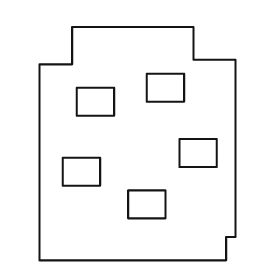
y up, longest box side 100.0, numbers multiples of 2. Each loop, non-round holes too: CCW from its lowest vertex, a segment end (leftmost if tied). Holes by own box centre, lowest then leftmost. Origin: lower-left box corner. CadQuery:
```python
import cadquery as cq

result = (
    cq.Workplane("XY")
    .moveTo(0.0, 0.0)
    .lineTo(80.0, 0.0)
    .lineTo(80.0, 10.0)
    .lineTo(84.0, 10.0)
    .lineTo(84.0, 86.0)
    .lineTo(66.0, 86.0)
    .lineTo(66.0, 100.0)
    .lineTo(14.0, 100.0)
    .lineTo(14.0, 84.0)
    .lineTo(0.0, 84.0)
    .close()
    .moveTo(38.0, 18.0)
    .lineTo(54.0, 18.0)
    .lineTo(54.0, 30.0)
    .lineTo(38.0, 30.0)
    .close()
    .moveTo(10.0, 32.0)
    .lineTo(26.0, 32.0)
    .lineTo(26.0, 44.0)
    .lineTo(10.0, 44.0)
    .close()
    .moveTo(60.0, 40.0)
    .lineTo(76.0, 40.0)
    .lineTo(76.0, 52.0)
    .lineTo(60.0, 52.0)
    .close()
    .moveTo(16.0, 62.0)
    .lineTo(32.0, 62.0)
    .lineTo(32.0, 74.0)
    .lineTo(16.0, 74.0)
    .close()
    .moveTo(46.0, 68.0)
    .lineTo(62.0, 68.0)
    .lineTo(62.0, 80.0)
    .lineTo(46.0, 80.0)
    .close()
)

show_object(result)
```